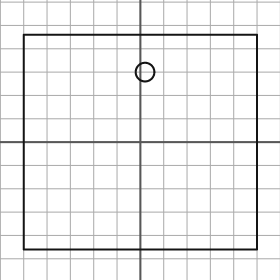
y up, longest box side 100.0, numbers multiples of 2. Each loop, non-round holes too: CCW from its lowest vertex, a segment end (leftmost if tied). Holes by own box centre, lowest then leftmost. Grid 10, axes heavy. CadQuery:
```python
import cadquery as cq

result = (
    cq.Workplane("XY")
    .moveTo(-50.0, -46.0)
    .lineTo(50.0, -46.0)
    .lineTo(50.0, 46.0)
    .lineTo(-50.0, 46.0)
    .close()
    .moveTo(2.0, 30.0)
    .circle(4.0)
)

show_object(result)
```